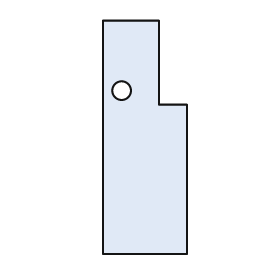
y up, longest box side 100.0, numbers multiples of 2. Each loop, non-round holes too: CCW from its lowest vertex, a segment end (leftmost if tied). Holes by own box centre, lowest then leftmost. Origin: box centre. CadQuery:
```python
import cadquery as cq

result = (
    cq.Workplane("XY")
    .moveTo(-18.0, -50.0)
    .lineTo(18.0, -50.0)
    .lineTo(18.0, 14.0)
    .lineTo(6.0, 14.0)
    .lineTo(6.0, 50.0)
    .lineTo(-18.0, 50.0)
    .close()
    .moveTo(-10.0, 20.0)
    .circle(4.0)
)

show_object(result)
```